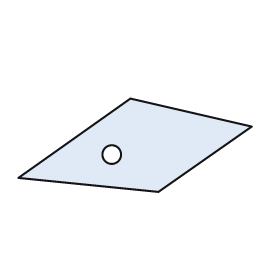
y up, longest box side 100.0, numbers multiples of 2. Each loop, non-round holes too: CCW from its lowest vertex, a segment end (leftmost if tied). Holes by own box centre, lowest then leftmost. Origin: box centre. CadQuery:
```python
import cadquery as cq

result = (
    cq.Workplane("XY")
    .moveTo(10.0, -20.0)
    .lineTo(50.0, 8.0)
    .lineTo(-2.0, 20.0)
    .lineTo(-50.0, -14.0)
    .close()
    .moveTo(-10.0, -4.0)
    .circle(4.0)
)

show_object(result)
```